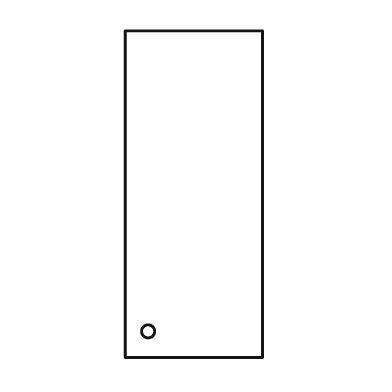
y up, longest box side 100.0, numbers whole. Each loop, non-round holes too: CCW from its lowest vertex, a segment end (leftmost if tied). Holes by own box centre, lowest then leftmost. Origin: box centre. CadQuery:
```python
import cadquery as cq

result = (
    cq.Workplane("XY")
    .moveTo(-21.0, -50.0)
    .lineTo(21.0, -50.0)
    .lineTo(21.0, 50.0)
    .lineTo(-21.0, 50.0)
    .close()
    .moveTo(-14.0, -42.0)
    .circle(2.0)
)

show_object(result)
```